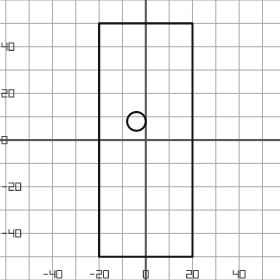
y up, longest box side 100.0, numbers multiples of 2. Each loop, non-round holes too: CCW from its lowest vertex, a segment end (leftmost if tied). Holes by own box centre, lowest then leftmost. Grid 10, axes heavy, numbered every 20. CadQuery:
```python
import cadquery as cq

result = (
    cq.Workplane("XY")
    .moveTo(-20.0, -50.0)
    .lineTo(20.0, -50.0)
    .lineTo(20.0, 50.0)
    .lineTo(-20.0, 50.0)
    .close()
    .moveTo(-4.0, 8.0)
    .circle(4.0)
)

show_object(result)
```